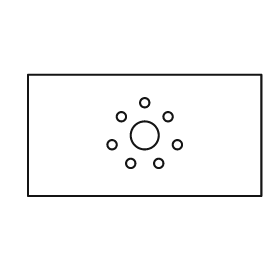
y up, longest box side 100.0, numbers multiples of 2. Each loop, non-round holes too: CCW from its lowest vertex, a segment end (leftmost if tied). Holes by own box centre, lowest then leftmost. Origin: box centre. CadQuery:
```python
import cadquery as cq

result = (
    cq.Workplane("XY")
    .moveTo(-50.0, -26.0)
    .lineTo(50.0, -26.0)
    .lineTo(50.0, 26.0)
    .lineTo(-50.0, 26.0)
    .close()
    .moveTo(-6.0, -12.0)
    .circle(2.0)
    .moveTo(6.0, -12.0)
    .circle(2.0)
    .moveTo(-14.0, -4.0)
    .circle(2.0)
    .moveTo(14.0, -4.0)
    .circle(2.0)
    .moveTo(0.0, 0.0)
    .circle(6.0)
    .moveTo(-10.0, 8.0)
    .circle(2.0)
    .moveTo(10.0, 8.0)
    .circle(2.0)
    .moveTo(0.0, 14.0)
    .circle(2.0)
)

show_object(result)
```